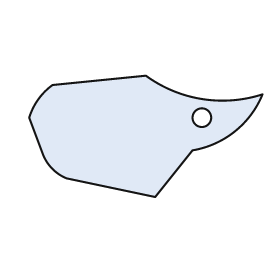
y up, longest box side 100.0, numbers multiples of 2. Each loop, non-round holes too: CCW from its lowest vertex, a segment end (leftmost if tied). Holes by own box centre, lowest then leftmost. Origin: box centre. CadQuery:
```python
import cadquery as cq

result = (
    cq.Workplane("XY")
    .moveTo(4.0, -26.0)
    .lineTo(20.0, -6.0)
    .threePointArc((38.0, 2.0), (50.0, 18.0))
    .threePointArc((24.0, 16.0), (0.0, 26.0))
    .lineTo(-40.0, 22.0)
    .threePointArc((-46.0, 16.0), (-50.0, 8.0))
    .lineTo(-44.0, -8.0)
    .threePointArc((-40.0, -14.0), (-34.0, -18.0))
    .close()
    .moveTo(24.0, 8.0)
    .circle(4.0)
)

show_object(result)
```